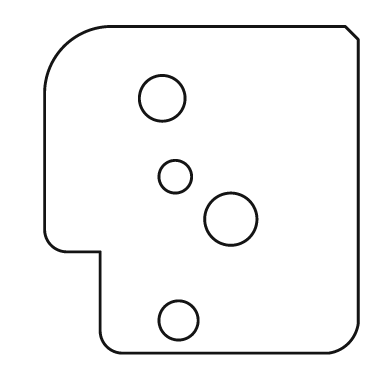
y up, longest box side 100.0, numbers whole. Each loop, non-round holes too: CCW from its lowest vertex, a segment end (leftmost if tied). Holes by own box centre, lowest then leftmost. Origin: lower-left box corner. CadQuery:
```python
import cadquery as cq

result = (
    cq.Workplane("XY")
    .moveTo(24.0, 0.0)
    .lineTo(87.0, 0.0)
    .threePointArc((93.0, 3.0), (96.0, 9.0))
    .lineTo(96.0, 96.0)
    .lineTo(92.0, 100.0)
    .lineTo(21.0, 100.0)
    .threePointArc((6.0, 94.0), (0.0, 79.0))
    .lineTo(0.0, 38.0)
    .threePointArc((2.0, 33.0), (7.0, 31.0))
    .lineTo(17.0, 31.0)
    .lineTo(17.0, 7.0)
    .threePointArc((19.0, 2.0), (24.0, 0.0))
    .close()
    .moveTo(41.0, 10.0)
    .circle(6.0)
    .moveTo(57.0, 41.0)
    .circle(8.0)
    .moveTo(40.0, 54.0)
    .circle(5.0)
    .moveTo(36.0, 78.0)
    .circle(7.0)
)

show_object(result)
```